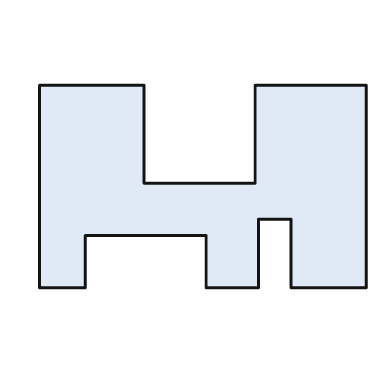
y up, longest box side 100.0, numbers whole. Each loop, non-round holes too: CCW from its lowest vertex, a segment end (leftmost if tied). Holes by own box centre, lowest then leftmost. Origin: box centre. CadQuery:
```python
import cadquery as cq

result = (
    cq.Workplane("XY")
    .moveTo(-50.0, -31.0)
    .lineTo(-36.0, -31.0)
    .lineTo(-36.0, -15.0)
    .lineTo(1.0, -15.0)
    .lineTo(1.0, -31.0)
    .lineTo(17.0, -31.0)
    .lineTo(17.0, -10.0)
    .lineTo(27.0, -10.0)
    .lineTo(27.0, -31.0)
    .lineTo(50.0, -31.0)
    .lineTo(50.0, 31.0)
    .lineTo(16.0, 31.0)
    .lineTo(16.0, 1.0)
    .lineTo(-18.0, 1.0)
    .lineTo(-18.0, 31.0)
    .lineTo(-50.0, 31.0)
    .close()
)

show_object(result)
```